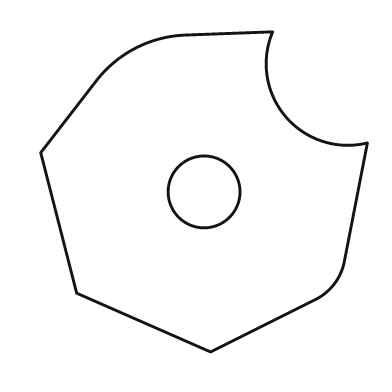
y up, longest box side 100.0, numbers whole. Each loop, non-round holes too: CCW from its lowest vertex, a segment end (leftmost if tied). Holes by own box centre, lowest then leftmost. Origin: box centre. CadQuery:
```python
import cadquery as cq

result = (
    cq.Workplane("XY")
    .moveTo(2.0, -49.0)
    .lineTo(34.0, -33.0)
    .threePointArc((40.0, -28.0), (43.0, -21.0))
    .lineTo(50.0, 15.0)
    .threePointArc((25.0, 23.0), (21.0, 49.0))
    .lineTo(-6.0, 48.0)
    .threePointArc((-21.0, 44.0), (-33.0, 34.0))
    .lineTo(-50.0, 12.0)
    .lineTo(-39.0, -31.0)
    .close()
    .moveTo(0.0, 0.0)
    .circle(11.0)
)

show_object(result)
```